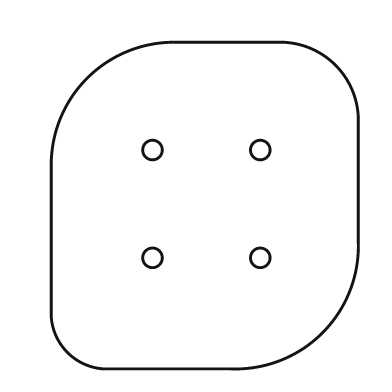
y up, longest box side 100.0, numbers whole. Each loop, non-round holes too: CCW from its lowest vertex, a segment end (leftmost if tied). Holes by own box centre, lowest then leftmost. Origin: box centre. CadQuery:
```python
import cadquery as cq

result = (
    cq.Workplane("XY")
    .moveTo(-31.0, -50.0)
    .lineTo(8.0, -50.0)
    .threePointArc((36.0, -39.0), (47.0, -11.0))
    .lineTo(47.0, 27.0)
    .threePointArc((40.0, 43.0), (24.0, 50.0))
    .lineTo(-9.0, 50.0)
    .threePointArc((-36.0, 39.0), (-47.0, 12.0))
    .lineTo(-47.0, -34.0)
    .threePointArc((-42.0, -45.0), (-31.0, -50.0))
    .close()
    .moveTo(-16.0, -16.0)
    .circle(3.0)
    .moveTo(17.0, -16.0)
    .circle(3.0)
    .moveTo(-16.0, 17.0)
    .circle(3.0)
    .moveTo(17.0, 17.0)
    .circle(3.0)
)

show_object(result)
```